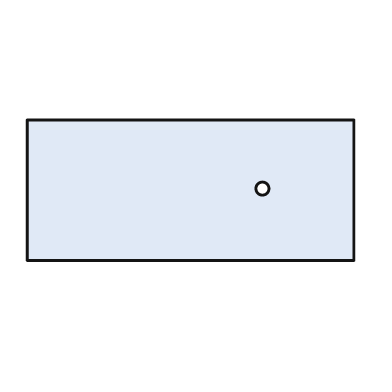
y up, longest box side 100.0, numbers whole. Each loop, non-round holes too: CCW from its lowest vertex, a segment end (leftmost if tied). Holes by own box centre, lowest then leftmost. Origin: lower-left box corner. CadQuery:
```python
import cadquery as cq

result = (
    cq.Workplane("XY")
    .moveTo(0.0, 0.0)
    .lineTo(100.0, 0.0)
    .lineTo(100.0, 43.0)
    .lineTo(0.0, 43.0)
    .close()
    .moveTo(72.0, 22.0)
    .circle(2.0)
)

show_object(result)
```